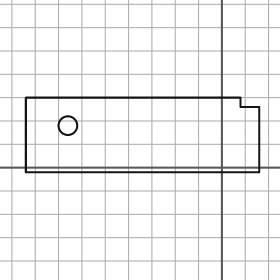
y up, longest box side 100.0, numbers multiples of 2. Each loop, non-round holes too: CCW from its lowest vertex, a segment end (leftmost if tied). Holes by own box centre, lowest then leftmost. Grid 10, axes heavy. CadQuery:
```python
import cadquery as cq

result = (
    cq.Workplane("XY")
    .moveTo(-84.0, -2.0)
    .lineTo(16.0, -2.0)
    .lineTo(16.0, 26.0)
    .lineTo(8.0, 26.0)
    .lineTo(8.0, 30.0)
    .lineTo(-84.0, 30.0)
    .close()
    .moveTo(-66.0, 18.0)
    .circle(4.0)
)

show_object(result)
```